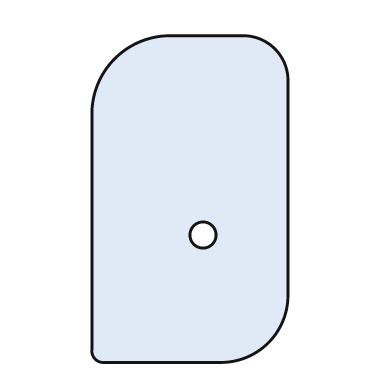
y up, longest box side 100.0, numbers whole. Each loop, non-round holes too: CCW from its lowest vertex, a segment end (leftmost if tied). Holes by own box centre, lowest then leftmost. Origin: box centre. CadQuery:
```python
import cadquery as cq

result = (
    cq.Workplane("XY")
    .moveTo(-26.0, -50.0)
    .lineTo(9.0, -50.0)
    .threePointArc((24.0, -44.0), (30.0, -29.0))
    .lineTo(30.0, 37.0)
    .threePointArc((26.0, 46.0), (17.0, 50.0))
    .lineTo(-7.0, 50.0)
    .threePointArc((-23.0, 43.0), (-30.0, 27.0))
    .lineTo(-30.0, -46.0)
    .threePointArc((-29.0, -49.0), (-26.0, -50.0))
    .close()
    .moveTo(4.0, -11.0)
    .circle(4.0)
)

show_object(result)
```